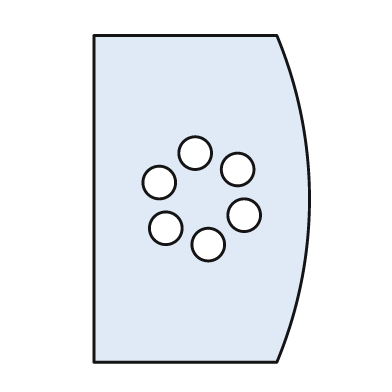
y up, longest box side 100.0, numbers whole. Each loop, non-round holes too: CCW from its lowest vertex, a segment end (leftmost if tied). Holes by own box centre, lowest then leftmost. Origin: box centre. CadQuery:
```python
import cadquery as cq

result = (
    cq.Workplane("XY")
    .moveTo(-33.0, -50.0)
    .lineTo(23.0, -50.0)
    .threePointArc((33.0, 0.0), (23.0, 50.0))
    .lineTo(-33.0, 50.0)
    .close()
    .moveTo(2.0, -14.0)
    .circle(5.0)
    .moveTo(-11.0, -9.0)
    .circle(5.0)
    .moveTo(13.0, -5.0)
    .circle(5.0)
    .moveTo(-13.0, 5.0)
    .circle(5.0)
    .moveTo(11.0, 9.0)
    .circle(5.0)
    .moveTo(-2.0, 14.0)
    .circle(5.0)
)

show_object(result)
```